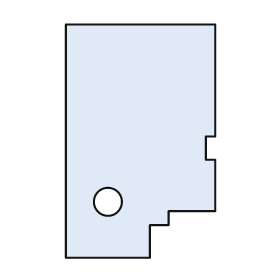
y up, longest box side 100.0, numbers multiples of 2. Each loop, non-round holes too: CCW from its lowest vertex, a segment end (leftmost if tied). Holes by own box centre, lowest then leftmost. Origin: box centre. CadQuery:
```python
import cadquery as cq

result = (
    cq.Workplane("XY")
    .moveTo(-32.0, -50.0)
    .lineTo(4.0, -50.0)
    .lineTo(4.0, -36.0)
    .lineTo(12.0, -36.0)
    .lineTo(12.0, -30.0)
    .lineTo(32.0, -30.0)
    .lineTo(32.0, -8.0)
    .lineTo(28.0, -8.0)
    .lineTo(28.0, 2.0)
    .lineTo(32.0, 2.0)
    .lineTo(32.0, 50.0)
    .lineTo(-32.0, 50.0)
    .close()
    .moveTo(-14.0, -26.0)
    .circle(6.0)
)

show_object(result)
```